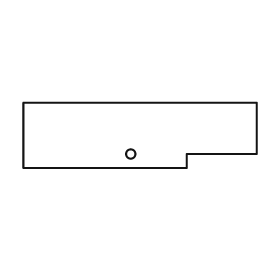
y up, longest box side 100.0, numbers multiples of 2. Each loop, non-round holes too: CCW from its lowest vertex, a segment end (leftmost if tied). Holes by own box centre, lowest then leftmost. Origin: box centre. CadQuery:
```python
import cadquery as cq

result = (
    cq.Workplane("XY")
    .moveTo(-50.0, -14.0)
    .lineTo(20.0, -14.0)
    .lineTo(20.0, -8.0)
    .lineTo(50.0, -8.0)
    .lineTo(50.0, 14.0)
    .lineTo(-50.0, 14.0)
    .close()
    .moveTo(-4.0, -8.0)
    .circle(2.0)
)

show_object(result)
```